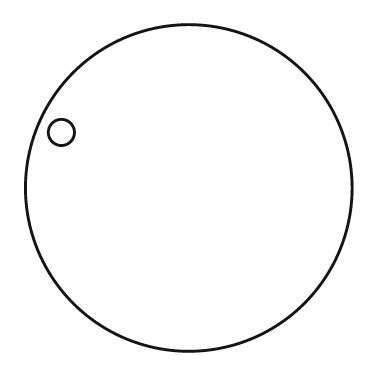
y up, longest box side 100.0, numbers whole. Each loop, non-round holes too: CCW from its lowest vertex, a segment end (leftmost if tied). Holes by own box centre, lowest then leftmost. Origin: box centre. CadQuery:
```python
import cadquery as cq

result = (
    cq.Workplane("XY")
    .moveTo(0.0, 0.0)
    .circle(50.0)
    .moveTo(-39.0, 17.0)
    .circle(4.0)
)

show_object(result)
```